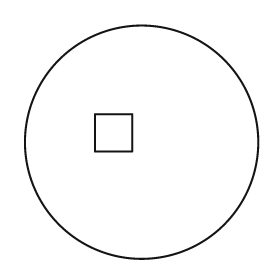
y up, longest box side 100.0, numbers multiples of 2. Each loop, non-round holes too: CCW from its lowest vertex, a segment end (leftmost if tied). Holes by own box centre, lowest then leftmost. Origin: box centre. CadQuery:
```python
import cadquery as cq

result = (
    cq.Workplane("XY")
    .moveTo(0.0, 0.0)
    .circle(50.0)
    .moveTo(-20.0, -4.0)
    .lineTo(-4.0, -4.0)
    .lineTo(-4.0, 12.0)
    .lineTo(-20.0, 12.0)
    .close()
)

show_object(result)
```